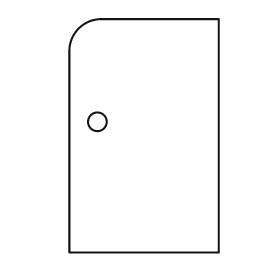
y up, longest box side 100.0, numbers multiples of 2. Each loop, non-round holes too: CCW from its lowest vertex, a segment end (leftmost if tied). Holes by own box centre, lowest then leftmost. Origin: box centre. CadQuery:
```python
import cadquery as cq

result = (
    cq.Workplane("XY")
    .moveTo(-32.0, -50.0)
    .lineTo(32.0, -50.0)
    .lineTo(32.0, 50.0)
    .lineTo(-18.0, 50.0)
    .threePointArc((-28.0, 46.0), (-32.0, 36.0))
    .close()
    .moveTo(-20.0, 6.0)
    .circle(4.0)
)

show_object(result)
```